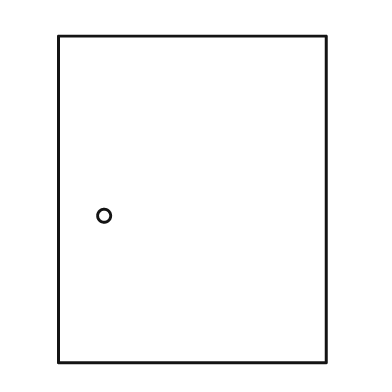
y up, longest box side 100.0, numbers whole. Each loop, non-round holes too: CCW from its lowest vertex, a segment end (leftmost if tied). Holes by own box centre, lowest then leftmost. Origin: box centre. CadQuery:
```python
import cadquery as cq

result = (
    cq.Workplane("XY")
    .moveTo(-41.0, -50.0)
    .lineTo(41.0, -50.0)
    .lineTo(41.0, 50.0)
    .lineTo(-41.0, 50.0)
    .close()
    .moveTo(-27.0, -5.0)
    .circle(2.0)
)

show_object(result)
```